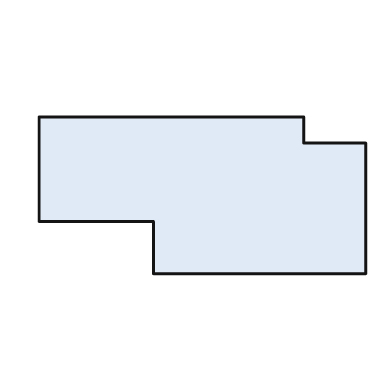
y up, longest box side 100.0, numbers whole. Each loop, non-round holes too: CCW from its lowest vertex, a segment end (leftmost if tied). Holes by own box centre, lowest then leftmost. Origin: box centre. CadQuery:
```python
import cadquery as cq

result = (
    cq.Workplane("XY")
    .moveTo(-15.0, -24.0)
    .lineTo(50.0, -24.0)
    .lineTo(50.0, 16.0)
    .lineTo(31.0, 16.0)
    .lineTo(31.0, 24.0)
    .lineTo(-50.0, 24.0)
    .lineTo(-50.0, -8.0)
    .lineTo(-15.0, -8.0)
    .close()
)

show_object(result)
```